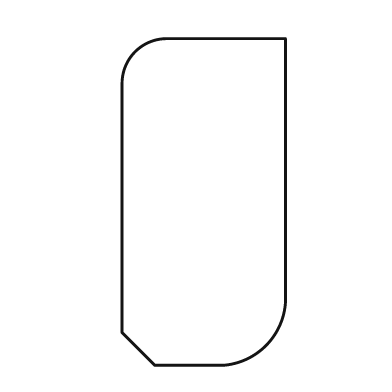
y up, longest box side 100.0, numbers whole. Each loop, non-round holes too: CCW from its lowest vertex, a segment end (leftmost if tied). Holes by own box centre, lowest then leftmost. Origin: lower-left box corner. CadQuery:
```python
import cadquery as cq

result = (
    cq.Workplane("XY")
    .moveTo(10.0, 0.0)
    .lineTo(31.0, 0.0)
    .threePointArc((44.0, 6.0), (50.0, 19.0))
    .lineTo(50.0, 100.0)
    .lineTo(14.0, 100.0)
    .threePointArc((4.0, 96.0), (0.0, 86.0))
    .lineTo(0.0, 10.0)
    .close()
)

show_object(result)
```